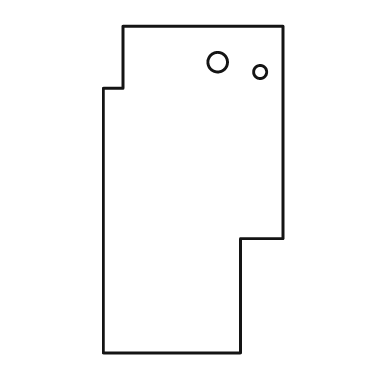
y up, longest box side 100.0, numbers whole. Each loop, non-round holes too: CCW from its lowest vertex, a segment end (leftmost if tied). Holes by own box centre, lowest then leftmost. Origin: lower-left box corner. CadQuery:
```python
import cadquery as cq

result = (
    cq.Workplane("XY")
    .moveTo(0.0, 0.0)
    .lineTo(42.0, 0.0)
    .lineTo(42.0, 35.0)
    .lineTo(55.0, 35.0)
    .lineTo(55.0, 100.0)
    .lineTo(6.0, 100.0)
    .lineTo(6.0, 81.0)
    .lineTo(0.0, 81.0)
    .close()
    .moveTo(48.0, 86.0)
    .circle(2.0)
    .moveTo(35.0, 89.0)
    .circle(3.0)
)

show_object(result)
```